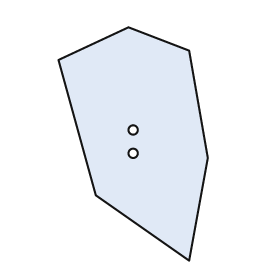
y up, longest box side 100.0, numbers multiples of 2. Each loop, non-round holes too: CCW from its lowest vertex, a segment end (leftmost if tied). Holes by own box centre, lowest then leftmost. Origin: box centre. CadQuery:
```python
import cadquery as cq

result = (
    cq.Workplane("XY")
    .moveTo(24.0, -50.0)
    .lineTo(32.0, -6.0)
    .lineTo(24.0, 40.0)
    .lineTo(-2.0, 50.0)
    .lineTo(-32.0, 36.0)
    .lineTo(-16.0, -22.0)
    .close()
    .moveTo(0.0, -4.0)
    .circle(2.0)
    .moveTo(0.0, 6.0)
    .circle(2.0)
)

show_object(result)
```